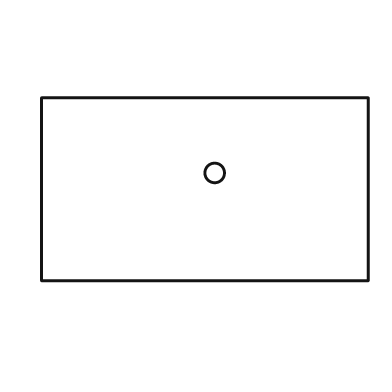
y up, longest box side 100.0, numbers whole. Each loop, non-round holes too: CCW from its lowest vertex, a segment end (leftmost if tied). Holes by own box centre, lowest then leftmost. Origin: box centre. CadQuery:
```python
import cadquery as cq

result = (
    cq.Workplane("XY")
    .moveTo(-50.0, -28.0)
    .lineTo(50.0, -28.0)
    .lineTo(50.0, 28.0)
    .lineTo(-50.0, 28.0)
    .close()
    .moveTo(3.0, 5.0)
    .circle(3.0)
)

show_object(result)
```